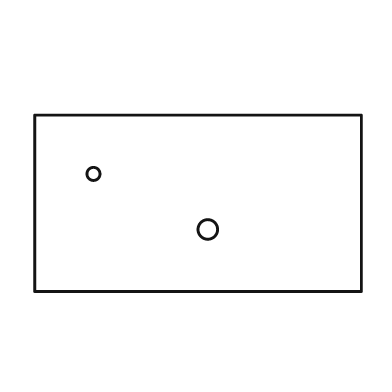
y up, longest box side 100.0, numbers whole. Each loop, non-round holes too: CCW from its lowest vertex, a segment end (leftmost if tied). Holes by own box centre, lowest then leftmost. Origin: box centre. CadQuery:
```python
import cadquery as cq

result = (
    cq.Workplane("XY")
    .moveTo(-50.0, -27.0)
    .lineTo(50.0, -27.0)
    .lineTo(50.0, 27.0)
    .lineTo(-50.0, 27.0)
    .close()
    .moveTo(3.0, -8.0)
    .circle(3.0)
    .moveTo(-32.0, 9.0)
    .circle(2.0)
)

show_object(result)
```